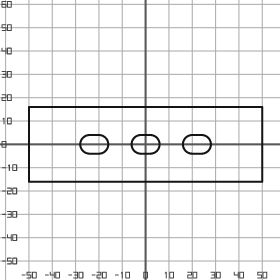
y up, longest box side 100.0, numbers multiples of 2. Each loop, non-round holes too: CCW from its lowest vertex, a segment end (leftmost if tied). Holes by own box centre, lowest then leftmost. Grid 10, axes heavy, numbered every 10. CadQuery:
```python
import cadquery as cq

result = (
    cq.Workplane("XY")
    .moveTo(-50.0, -16.0)
    .lineTo(50.0, -16.0)
    .lineTo(50.0, 16.0)
    .lineTo(-50.0, 16.0)
    .close()
    .moveTo(-24.0, -4.0)
    .lineTo(-20.0, -4.0)
    .threePointArc((-16.0, 0.0), (-20.0, 4.0))
    .lineTo(-24.0, 4.0)
    .threePointArc((-28.0, 0.0), (-24.0, -4.0))
    .close()
    .moveTo(-2.0, -4.0)
    .lineTo(2.0, -4.0)
    .threePointArc((6.0, 0.0), (2.0, 4.0))
    .lineTo(-2.0, 4.0)
    .threePointArc((-6.0, 0.0), (-2.0, -4.0))
    .close()
    .moveTo(20.0, -4.0)
    .lineTo(24.0, -4.0)
    .threePointArc((28.0, 0.0), (24.0, 4.0))
    .lineTo(20.0, 4.0)
    .threePointArc((16.0, 0.0), (20.0, -4.0))
    .close()
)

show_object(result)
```